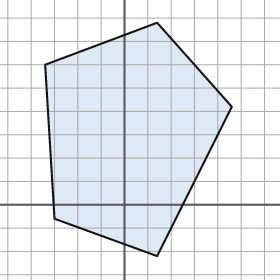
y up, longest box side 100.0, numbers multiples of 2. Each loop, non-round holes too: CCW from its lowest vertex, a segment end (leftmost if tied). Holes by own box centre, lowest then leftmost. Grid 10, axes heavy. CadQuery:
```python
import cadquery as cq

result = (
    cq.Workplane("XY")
    .moveTo(14.0, -22.0)
    .lineTo(46.0, 42.0)
    .lineTo(14.0, 78.0)
    .lineTo(-34.0, 60.0)
    .lineTo(-30.0, -6.0)
    .close()
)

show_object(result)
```